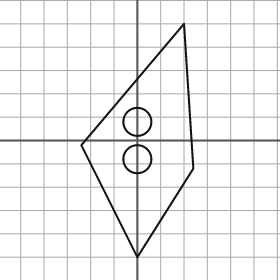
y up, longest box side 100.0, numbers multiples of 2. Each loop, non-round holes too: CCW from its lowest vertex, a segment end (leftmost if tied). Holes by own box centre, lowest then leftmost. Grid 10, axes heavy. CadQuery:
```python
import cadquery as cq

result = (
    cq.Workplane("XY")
    .moveTo(0.0, -50.0)
    .lineTo(24.0, -12.0)
    .lineTo(20.0, 50.0)
    .lineTo(-24.0, -2.0)
    .close()
    .moveTo(0.0, -8.0)
    .circle(6.0)
    .moveTo(0.0, 8.0)
    .circle(6.0)
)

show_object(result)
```